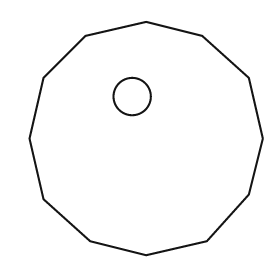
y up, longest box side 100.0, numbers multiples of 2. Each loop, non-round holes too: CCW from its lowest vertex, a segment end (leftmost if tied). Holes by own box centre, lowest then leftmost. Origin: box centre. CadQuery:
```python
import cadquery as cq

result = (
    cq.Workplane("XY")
    .moveTo(0.0, -50.0)
    .lineTo(26.0, -44.0)
    .lineTo(44.0, -24.0)
    .lineTo(50.0, 0.0)
    .lineTo(44.0, 26.0)
    .lineTo(24.0, 44.0)
    .lineTo(0.0, 50.0)
    .lineTo(-26.0, 44.0)
    .lineTo(-44.0, 26.0)
    .lineTo(-50.0, 0.0)
    .lineTo(-44.0, -26.0)
    .lineTo(-24.0, -44.0)
    .close()
    .moveTo(-6.0, 18.0)
    .circle(8.0)
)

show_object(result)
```